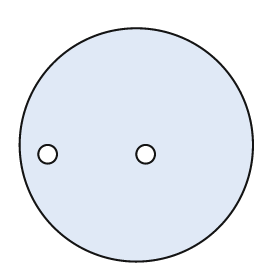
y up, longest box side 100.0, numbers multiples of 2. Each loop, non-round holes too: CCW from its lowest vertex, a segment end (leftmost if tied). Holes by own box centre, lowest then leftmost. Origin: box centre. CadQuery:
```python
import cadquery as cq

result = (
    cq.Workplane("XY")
    .moveTo(0.0, 0.0)
    .circle(50.0)
    .moveTo(-38.0, -4.0)
    .circle(4.0)
    .moveTo(4.0, -4.0)
    .circle(4.0)
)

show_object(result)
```